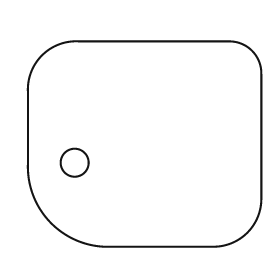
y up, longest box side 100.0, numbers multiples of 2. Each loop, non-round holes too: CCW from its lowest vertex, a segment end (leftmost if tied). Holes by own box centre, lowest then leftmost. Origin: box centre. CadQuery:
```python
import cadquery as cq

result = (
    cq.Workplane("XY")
    .moveTo(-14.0, -44.0)
    .lineTo(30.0, -44.0)
    .threePointArc((44.0, -38.0), (50.0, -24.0))
    .lineTo(50.0, 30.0)
    .threePointArc((46.0, 40.0), (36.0, 44.0))
    .lineTo(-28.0, 44.0)
    .threePointArc((-44.0, 38.0), (-50.0, 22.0))
    .lineTo(-50.0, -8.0)
    .threePointArc((-40.0, -34.0), (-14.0, -44.0))
    .close()
    .moveTo(-30.0, -8.0)
    .circle(6.0)
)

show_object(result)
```